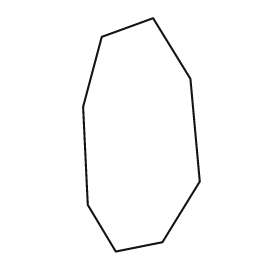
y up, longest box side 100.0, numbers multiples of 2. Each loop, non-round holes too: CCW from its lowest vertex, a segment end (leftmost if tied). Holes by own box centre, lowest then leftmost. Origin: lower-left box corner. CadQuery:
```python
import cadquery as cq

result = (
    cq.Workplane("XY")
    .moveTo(14.0, 0.0)
    .lineTo(34.0, 4.0)
    .lineTo(50.0, 30.0)
    .lineTo(46.0, 74.0)
    .lineTo(30.0, 100.0)
    .lineTo(8.0, 92.0)
    .lineTo(0.0, 62.0)
    .lineTo(2.0, 20.0)
    .close()
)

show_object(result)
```